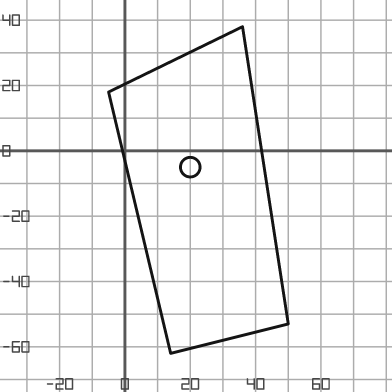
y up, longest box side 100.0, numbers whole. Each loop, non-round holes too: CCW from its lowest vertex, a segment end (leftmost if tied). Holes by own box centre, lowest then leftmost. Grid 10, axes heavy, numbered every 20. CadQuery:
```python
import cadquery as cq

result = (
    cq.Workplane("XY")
    .moveTo(14.0, -62.0)
    .lineTo(50.0, -53.0)
    .lineTo(36.0, 38.0)
    .lineTo(-5.0, 18.0)
    .close()
    .moveTo(20.0, -5.0)
    .circle(3.0)
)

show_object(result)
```